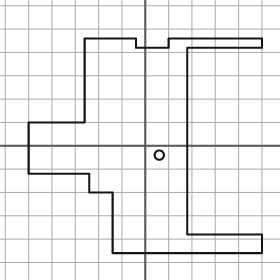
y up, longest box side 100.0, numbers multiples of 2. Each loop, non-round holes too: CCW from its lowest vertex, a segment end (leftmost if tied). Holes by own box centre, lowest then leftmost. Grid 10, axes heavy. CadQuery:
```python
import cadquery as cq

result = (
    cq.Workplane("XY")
    .moveTo(-14.0, -46.0)
    .lineTo(50.0, -46.0)
    .lineTo(50.0, -38.0)
    .lineTo(18.0, -38.0)
    .lineTo(18.0, 42.0)
    .lineTo(50.0, 42.0)
    .lineTo(50.0, 46.0)
    .lineTo(10.0, 46.0)
    .lineTo(10.0, 42.0)
    .lineTo(-4.0, 42.0)
    .lineTo(-4.0, 46.0)
    .lineTo(-26.0, 46.0)
    .lineTo(-26.0, 10.0)
    .lineTo(-50.0, 10.0)
    .lineTo(-50.0, -12.0)
    .lineTo(-24.0, -12.0)
    .lineTo(-24.0, -20.0)
    .lineTo(-14.0, -20.0)
    .close()
    .moveTo(6.0, -4.0)
    .circle(2.0)
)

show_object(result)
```